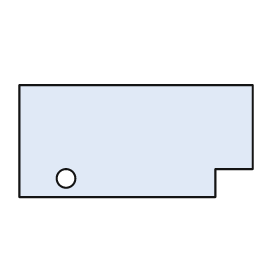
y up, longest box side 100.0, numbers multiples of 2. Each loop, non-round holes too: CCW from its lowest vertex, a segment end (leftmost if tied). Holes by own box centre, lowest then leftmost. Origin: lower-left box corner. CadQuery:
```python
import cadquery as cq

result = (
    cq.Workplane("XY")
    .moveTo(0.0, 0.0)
    .lineTo(84.0, 0.0)
    .lineTo(84.0, 12.0)
    .lineTo(100.0, 12.0)
    .lineTo(100.0, 48.0)
    .lineTo(0.0, 48.0)
    .close()
    .moveTo(20.0, 8.0)
    .circle(4.0)
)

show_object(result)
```